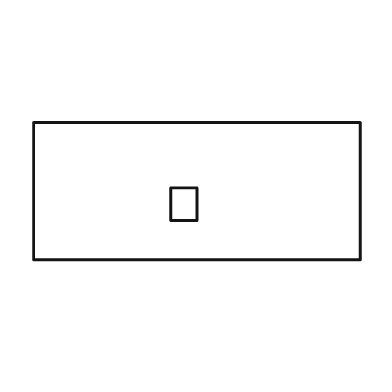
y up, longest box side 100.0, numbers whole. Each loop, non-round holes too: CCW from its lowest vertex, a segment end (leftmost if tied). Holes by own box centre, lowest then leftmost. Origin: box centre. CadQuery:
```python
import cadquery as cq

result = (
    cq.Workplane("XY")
    .moveTo(-50.0, -21.0)
    .lineTo(50.0, -21.0)
    .lineTo(50.0, 21.0)
    .lineTo(-50.0, 21.0)
    .close()
    .moveTo(-8.0, -9.0)
    .lineTo(0.0, -9.0)
    .lineTo(0.0, 1.0)
    .lineTo(-8.0, 1.0)
    .close()
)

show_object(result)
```